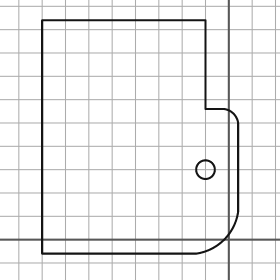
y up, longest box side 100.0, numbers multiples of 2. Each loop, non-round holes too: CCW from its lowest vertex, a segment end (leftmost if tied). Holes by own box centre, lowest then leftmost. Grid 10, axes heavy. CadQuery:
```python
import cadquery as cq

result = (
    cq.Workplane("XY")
    .moveTo(-80.0, -6.0)
    .lineTo(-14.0, -6.0)
    .threePointArc((-2.0, 0.0), (4.0, 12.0))
    .lineTo(4.0, 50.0)
    .threePointArc((2.0, 54.0), (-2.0, 56.0))
    .lineTo(-10.0, 56.0)
    .lineTo(-10.0, 94.0)
    .lineTo(-80.0, 94.0)
    .close()
    .moveTo(-10.0, 30.0)
    .circle(4.0)
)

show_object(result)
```